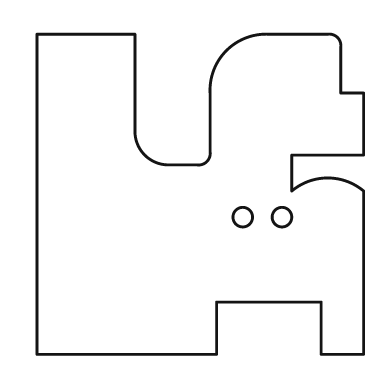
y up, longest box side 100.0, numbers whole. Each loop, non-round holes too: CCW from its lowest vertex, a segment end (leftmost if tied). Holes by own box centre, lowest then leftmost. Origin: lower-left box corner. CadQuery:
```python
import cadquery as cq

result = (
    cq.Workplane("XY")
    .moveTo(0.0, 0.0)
    .lineTo(55.0, 0.0)
    .lineTo(55.0, 16.0)
    .lineTo(87.0, 16.0)
    .lineTo(87.0, 0.0)
    .lineTo(100.0, 0.0)
    .lineTo(100.0, 50.0)
    .threePointArc((89.0, 54.0), (78.0, 50.0))
    .lineTo(78.0, 61.0)
    .lineTo(100.0, 61.0)
    .lineTo(100.0, 80.0)
    .lineTo(93.0, 80.0)
    .lineTo(93.0, 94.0)
    .threePointArc((92.0, 97.0), (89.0, 98.0))
    .lineTo(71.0, 98.0)
    .threePointArc((58.0, 93.0), (53.0, 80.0))
    .lineTo(53.0, 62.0)
    .threePointArc((52.0, 59.0), (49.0, 58.0))
    .lineTo(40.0, 58.0)
    .threePointArc((33.0, 61.0), (30.0, 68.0))
    .lineTo(30.0, 98.0)
    .lineTo(0.0, 98.0)
    .close()
    .moveTo(63.0, 42.0)
    .circle(3.0)
    .moveTo(75.0, 42.0)
    .circle(3.0)
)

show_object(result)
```